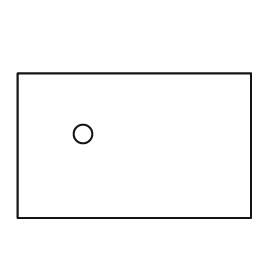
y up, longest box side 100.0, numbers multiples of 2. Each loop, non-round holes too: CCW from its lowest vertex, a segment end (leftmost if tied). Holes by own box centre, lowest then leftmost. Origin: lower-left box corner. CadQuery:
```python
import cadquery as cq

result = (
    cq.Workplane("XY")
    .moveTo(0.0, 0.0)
    .lineTo(100.0, 0.0)
    .lineTo(100.0, 62.0)
    .lineTo(0.0, 62.0)
    .close()
    .moveTo(28.0, 36.0)
    .circle(4.0)
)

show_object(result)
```